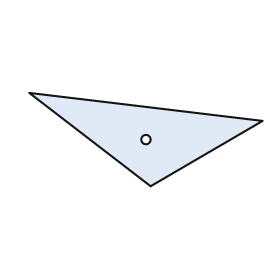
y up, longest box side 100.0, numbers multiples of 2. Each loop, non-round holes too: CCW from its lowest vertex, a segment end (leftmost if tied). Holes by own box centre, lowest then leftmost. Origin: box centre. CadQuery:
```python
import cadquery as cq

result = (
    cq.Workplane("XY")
    .moveTo(2.0, -20.0)
    .lineTo(50.0, 8.0)
    .lineTo(-50.0, 20.0)
    .close()
    .moveTo(0.0, 0.0)
    .circle(2.0)
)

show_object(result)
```